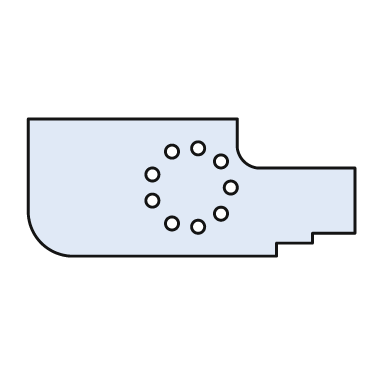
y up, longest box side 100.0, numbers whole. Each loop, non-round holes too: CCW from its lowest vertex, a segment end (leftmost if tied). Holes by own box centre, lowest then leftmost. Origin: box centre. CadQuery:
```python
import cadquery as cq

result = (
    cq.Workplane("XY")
    .moveTo(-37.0, -21.0)
    .lineTo(26.0, -21.0)
    .lineTo(26.0, -17.0)
    .lineTo(37.0, -17.0)
    .lineTo(37.0, -14.0)
    .lineTo(50.0, -14.0)
    .lineTo(50.0, 6.0)
    .lineTo(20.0, 6.0)
    .threePointArc((16.0, 8.0), (14.0, 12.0))
    .lineTo(14.0, 21.0)
    .lineTo(-50.0, 21.0)
    .lineTo(-50.0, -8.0)
    .threePointArc((-46.0, -17.0), (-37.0, -21.0))
    .close()
    .moveTo(2.0, -12.0)
    .circle(2.0)
    .moveTo(-6.0, -11.0)
    .circle(2.0)
    .moveTo(9.0, -8.0)
    .circle(2.0)
    .moveTo(-12.0, -4.0)
    .circle(2.0)
    .moveTo(12.0, 0.0)
    .circle(2.0)
    .moveTo(-12.0, 4.0)
    .circle(2.0)
    .moveTo(9.0, 8.0)
    .circle(2.0)
    .moveTo(-6.0, 11.0)
    .circle(2.0)
    .moveTo(2.0, 12.0)
    .circle(2.0)
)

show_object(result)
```